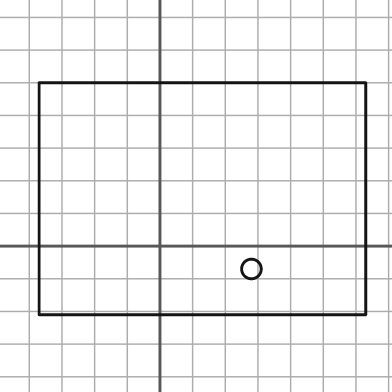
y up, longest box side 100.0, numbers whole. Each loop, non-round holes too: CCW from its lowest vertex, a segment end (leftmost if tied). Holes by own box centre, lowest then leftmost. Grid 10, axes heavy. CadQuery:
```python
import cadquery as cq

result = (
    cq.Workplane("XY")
    .moveTo(-37.0, -21.0)
    .lineTo(63.0, -21.0)
    .lineTo(63.0, 50.0)
    .lineTo(-37.0, 50.0)
    .close()
    .moveTo(28.0, -7.0)
    .circle(3.0)
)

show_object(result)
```